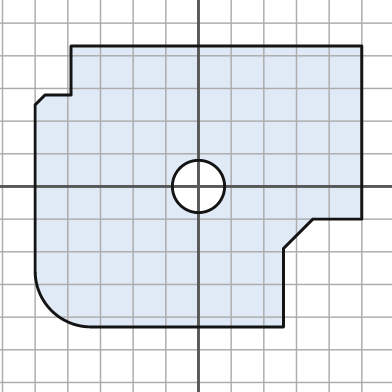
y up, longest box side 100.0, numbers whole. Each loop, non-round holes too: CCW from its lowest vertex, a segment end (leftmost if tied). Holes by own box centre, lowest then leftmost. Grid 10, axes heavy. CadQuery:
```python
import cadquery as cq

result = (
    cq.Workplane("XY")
    .moveTo(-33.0, -43.0)
    .lineTo(26.0, -43.0)
    .lineTo(26.0, -19.0)
    .lineTo(35.0, -10.0)
    .lineTo(50.0, -10.0)
    .lineTo(50.0, 43.0)
    .lineTo(-39.0, 43.0)
    .lineTo(-39.0, 28.0)
    .lineTo(-47.0, 28.0)
    .lineTo(-50.0, 25.0)
    .lineTo(-50.0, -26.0)
    .threePointArc((-45.0, -38.0), (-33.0, -43.0))
    .close()
    .moveTo(0.0, 0.0)
    .circle(8.0)
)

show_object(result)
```